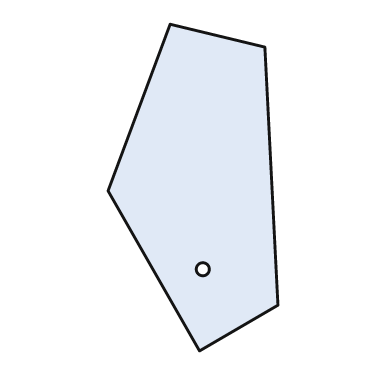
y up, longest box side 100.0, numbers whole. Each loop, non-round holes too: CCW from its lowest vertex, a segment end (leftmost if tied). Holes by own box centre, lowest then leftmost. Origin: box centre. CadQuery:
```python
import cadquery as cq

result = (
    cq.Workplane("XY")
    .moveTo(2.0, -50.0)
    .lineTo(26.0, -36.0)
    .lineTo(22.0, 43.0)
    .lineTo(-7.0, 50.0)
    .lineTo(-26.0, -1.0)
    .close()
    .moveTo(3.0, -25.0)
    .circle(2.0)
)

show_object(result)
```